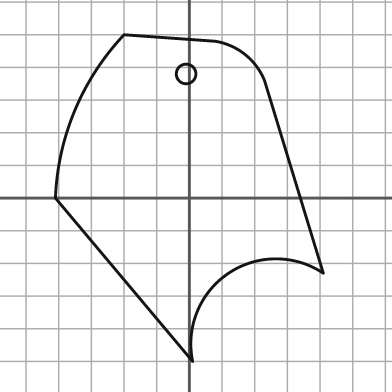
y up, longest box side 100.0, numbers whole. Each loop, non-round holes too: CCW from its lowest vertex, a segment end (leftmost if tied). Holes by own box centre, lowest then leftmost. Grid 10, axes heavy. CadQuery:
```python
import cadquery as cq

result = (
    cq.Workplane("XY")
    .moveTo(1.0, -50.0)
    .threePointArc((12.0, -23.0), (41.0, -23.0))
    .lineTo(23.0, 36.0)
    .threePointArc((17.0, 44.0), (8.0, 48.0))
    .lineTo(-20.0, 50.0)
    .threePointArc((-35.0, 27.0), (-41.0, 0.0))
    .close()
    .moveTo(-1.0, 38.0)
    .circle(3.0)
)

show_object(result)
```